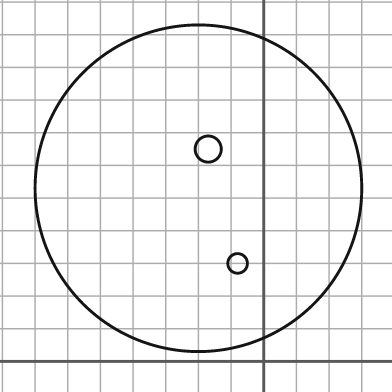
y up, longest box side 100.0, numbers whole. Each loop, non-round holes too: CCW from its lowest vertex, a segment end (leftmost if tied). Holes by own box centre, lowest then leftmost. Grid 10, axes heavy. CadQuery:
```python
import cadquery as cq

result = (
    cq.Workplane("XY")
    .moveTo(-20.0, 53.0)
    .circle(50.0)
    .moveTo(-8.0, 30.0)
    .circle(3.0)
    .moveTo(-17.0, 65.0)
    .circle(4.0)
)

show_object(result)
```